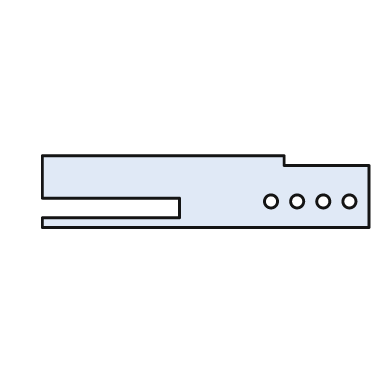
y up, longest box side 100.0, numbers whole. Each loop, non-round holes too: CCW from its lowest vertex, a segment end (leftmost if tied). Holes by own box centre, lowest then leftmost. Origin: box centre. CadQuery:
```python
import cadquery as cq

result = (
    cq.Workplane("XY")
    .moveTo(-50.0, -11.0)
    .lineTo(50.0, -11.0)
    .lineTo(50.0, 8.0)
    .lineTo(24.0, 8.0)
    .lineTo(24.0, 11.0)
    .lineTo(-50.0, 11.0)
    .lineTo(-50.0, -2.0)
    .lineTo(-8.0, -2.0)
    .lineTo(-8.0, -8.0)
    .lineTo(-50.0, -8.0)
    .close()
    .moveTo(20.0, -3.0)
    .circle(2.0)
    .moveTo(28.0, -3.0)
    .circle(2.0)
    .moveTo(36.0, -3.0)
    .circle(2.0)
    .moveTo(44.0, -3.0)
    .circle(2.0)
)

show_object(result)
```